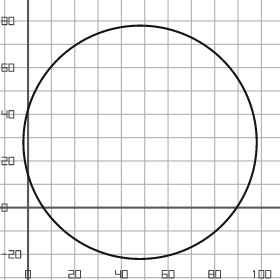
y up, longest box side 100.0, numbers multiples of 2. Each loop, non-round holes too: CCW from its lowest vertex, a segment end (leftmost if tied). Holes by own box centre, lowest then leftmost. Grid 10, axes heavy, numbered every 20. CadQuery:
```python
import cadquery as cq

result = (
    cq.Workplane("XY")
    .moveTo(48.0, 28.0)
    .circle(50.0)
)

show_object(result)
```